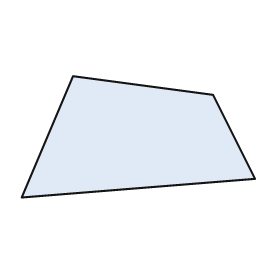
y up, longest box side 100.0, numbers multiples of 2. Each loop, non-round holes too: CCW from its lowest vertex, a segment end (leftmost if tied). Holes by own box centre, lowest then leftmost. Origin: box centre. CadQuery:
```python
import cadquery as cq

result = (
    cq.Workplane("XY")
    .moveTo(-50.0, -26.0)
    .lineTo(50.0, -18.0)
    .lineTo(32.0, 18.0)
    .lineTo(-28.0, 26.0)
    .close()
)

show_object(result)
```